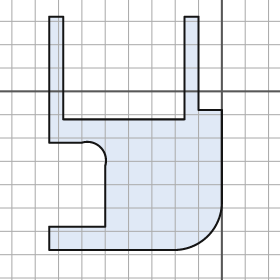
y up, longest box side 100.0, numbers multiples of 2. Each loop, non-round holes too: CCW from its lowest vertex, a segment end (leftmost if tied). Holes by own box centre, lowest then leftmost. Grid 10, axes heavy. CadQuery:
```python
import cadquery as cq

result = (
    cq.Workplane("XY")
    .moveTo(-74.0, -68.0)
    .lineTo(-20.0, -68.0)
    .threePointArc((-6.0, -62.0), (0.0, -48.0))
    .lineTo(0.0, -8.0)
    .lineTo(-10.0, -8.0)
    .lineTo(-10.0, 32.0)
    .lineTo(-16.0, 32.0)
    .lineTo(-16.0, -12.0)
    .lineTo(-68.0, -12.0)
    .lineTo(-68.0, 32.0)
    .lineTo(-74.0, 32.0)
    .lineTo(-74.0, -22.0)
    .lineTo(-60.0, -22.0)
    .threePointArc((-52.0, -24.0), (-50.0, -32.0))
    .lineTo(-50.0, -58.0)
    .lineTo(-74.0, -58.0)
    .close()
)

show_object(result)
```